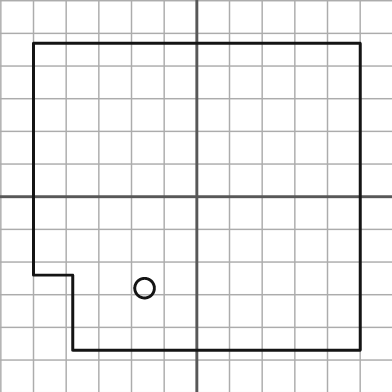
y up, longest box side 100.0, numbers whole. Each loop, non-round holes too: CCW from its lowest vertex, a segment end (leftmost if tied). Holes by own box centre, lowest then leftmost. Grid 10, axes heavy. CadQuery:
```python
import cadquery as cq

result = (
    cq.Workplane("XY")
    .moveTo(-38.0, -47.0)
    .lineTo(50.0, -47.0)
    .lineTo(50.0, 47.0)
    .lineTo(-50.0, 47.0)
    .lineTo(-50.0, -24.0)
    .lineTo(-38.0, -24.0)
    .close()
    .moveTo(-16.0, -28.0)
    .circle(3.0)
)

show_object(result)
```